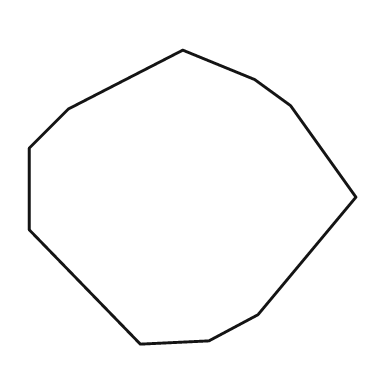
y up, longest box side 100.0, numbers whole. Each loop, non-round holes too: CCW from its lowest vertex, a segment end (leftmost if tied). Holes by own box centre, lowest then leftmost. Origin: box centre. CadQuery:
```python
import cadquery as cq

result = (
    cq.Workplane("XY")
    .moveTo(-16.0, -45.0)
    .lineTo(5.0, -44.0)
    .lineTo(20.0, -36.0)
    .lineTo(50.0, 0.0)
    .lineTo(30.0, 28.0)
    .lineTo(19.0, 36.0)
    .lineTo(-3.0, 45.0)
    .lineTo(-38.0, 27.0)
    .lineTo(-50.0, 15.0)
    .lineTo(-50.0, -10.0)
    .close()
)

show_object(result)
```